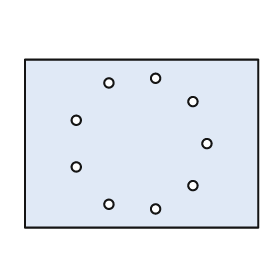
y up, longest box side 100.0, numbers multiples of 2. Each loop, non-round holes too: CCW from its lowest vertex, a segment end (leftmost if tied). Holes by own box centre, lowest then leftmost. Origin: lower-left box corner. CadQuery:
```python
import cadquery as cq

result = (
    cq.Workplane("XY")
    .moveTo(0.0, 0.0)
    .lineTo(100.0, 0.0)
    .lineTo(100.0, 72.0)
    .lineTo(0.0, 72.0)
    .close()
    .moveTo(56.0, 8.0)
    .circle(2.0)
    .moveTo(36.0, 10.0)
    .circle(2.0)
    .moveTo(72.0, 18.0)
    .circle(2.0)
    .moveTo(22.0, 26.0)
    .circle(2.0)
    .moveTo(78.0, 36.0)
    .circle(2.0)
    .moveTo(22.0, 46.0)
    .circle(2.0)
    .moveTo(72.0, 54.0)
    .circle(2.0)
    .moveTo(36.0, 62.0)
    .circle(2.0)
    .moveTo(56.0, 64.0)
    .circle(2.0)
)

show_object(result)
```